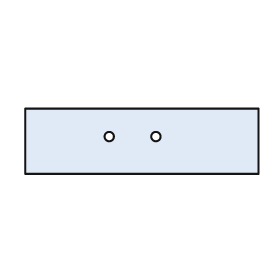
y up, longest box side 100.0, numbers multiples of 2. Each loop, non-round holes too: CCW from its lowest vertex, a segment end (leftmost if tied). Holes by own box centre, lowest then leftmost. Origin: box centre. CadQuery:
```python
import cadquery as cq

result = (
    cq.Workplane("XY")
    .moveTo(-50.0, -14.0)
    .lineTo(50.0, -14.0)
    .lineTo(50.0, 14.0)
    .lineTo(-50.0, 14.0)
    .close()
    .moveTo(-14.0, 2.0)
    .circle(2.0)
    .moveTo(6.0, 2.0)
    .circle(2.0)
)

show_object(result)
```